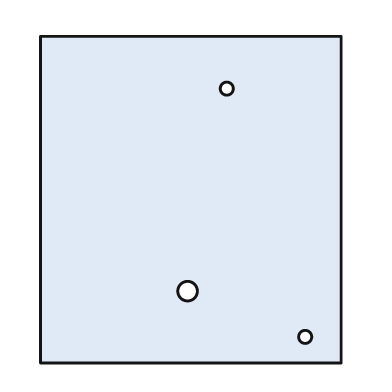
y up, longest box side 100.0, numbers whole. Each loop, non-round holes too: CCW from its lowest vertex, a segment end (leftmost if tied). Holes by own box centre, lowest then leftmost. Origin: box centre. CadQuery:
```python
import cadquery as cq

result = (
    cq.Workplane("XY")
    .moveTo(-46.0, -50.0)
    .lineTo(46.0, -50.0)
    .lineTo(46.0, 50.0)
    .lineTo(-46.0, 50.0)
    .close()
    .moveTo(35.0, -42.0)
    .circle(2.0)
    .moveTo(-1.0, -28.0)
    .circle(3.0)
    .moveTo(11.0, 34.0)
    .circle(2.0)
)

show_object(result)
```